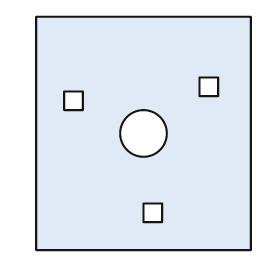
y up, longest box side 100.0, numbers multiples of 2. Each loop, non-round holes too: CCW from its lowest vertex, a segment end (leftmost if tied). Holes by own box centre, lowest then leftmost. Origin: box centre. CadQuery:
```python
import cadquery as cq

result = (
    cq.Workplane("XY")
    .moveTo(-46.0, -50.0)
    .lineTo(46.0, -50.0)
    .lineTo(46.0, 50.0)
    .lineTo(-46.0, 50.0)
    .close()
    .moveTo(0.0, -38.0)
    .lineTo(8.0, -38.0)
    .lineTo(8.0, -30.0)
    .lineTo(0.0, -30.0)
    .close()
    .moveTo(0.0, 0.0)
    .circle(10.0)
    .moveTo(-34.0, 10.0)
    .lineTo(-26.0, 10.0)
    .lineTo(-26.0, 18.0)
    .lineTo(-34.0, 18.0)
    .close()
    .moveTo(24.0, 16.0)
    .lineTo(32.0, 16.0)
    .lineTo(32.0, 24.0)
    .lineTo(24.0, 24.0)
    .close()
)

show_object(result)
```